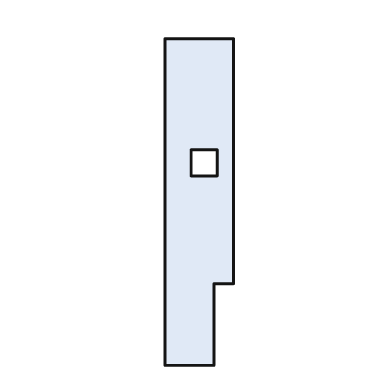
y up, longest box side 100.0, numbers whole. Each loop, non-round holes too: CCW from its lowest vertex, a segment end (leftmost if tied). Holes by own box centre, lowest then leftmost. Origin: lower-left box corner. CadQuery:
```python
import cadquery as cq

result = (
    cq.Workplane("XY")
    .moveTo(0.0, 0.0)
    .lineTo(15.0, 0.0)
    .lineTo(15.0, 25.0)
    .lineTo(21.0, 25.0)
    .lineTo(21.0, 100.0)
    .lineTo(0.0, 100.0)
    .close()
    .moveTo(8.0, 58.0)
    .lineTo(16.0, 58.0)
    .lineTo(16.0, 66.0)
    .lineTo(8.0, 66.0)
    .close()
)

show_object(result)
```